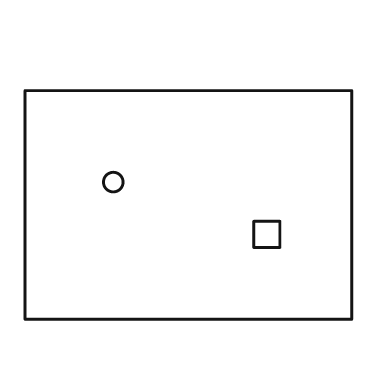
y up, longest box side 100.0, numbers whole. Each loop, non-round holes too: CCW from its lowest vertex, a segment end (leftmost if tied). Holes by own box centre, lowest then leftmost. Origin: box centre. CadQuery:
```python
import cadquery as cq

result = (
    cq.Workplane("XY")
    .moveTo(-50.0, -35.0)
    .lineTo(50.0, -35.0)
    .lineTo(50.0, 35.0)
    .lineTo(-50.0, 35.0)
    .close()
    .moveTo(20.0, -13.0)
    .lineTo(28.0, -13.0)
    .lineTo(28.0, -5.0)
    .lineTo(20.0, -5.0)
    .close()
    .moveTo(-23.0, 7.0)
    .circle(3.0)
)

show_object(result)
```